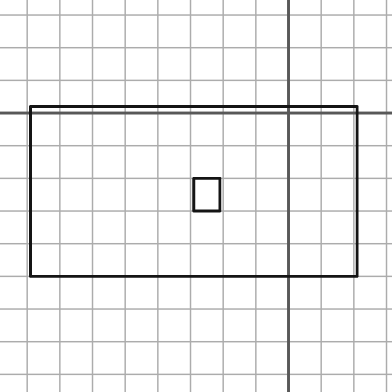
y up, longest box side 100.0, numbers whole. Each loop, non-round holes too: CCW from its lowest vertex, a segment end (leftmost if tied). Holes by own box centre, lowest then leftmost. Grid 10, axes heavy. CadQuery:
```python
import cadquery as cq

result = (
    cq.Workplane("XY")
    .moveTo(-79.0, -50.0)
    .lineTo(21.0, -50.0)
    .lineTo(21.0, 2.0)
    .lineTo(-79.0, 2.0)
    .close()
    .moveTo(-29.0, -30.0)
    .lineTo(-21.0, -30.0)
    .lineTo(-21.0, -20.0)
    .lineTo(-29.0, -20.0)
    .close()
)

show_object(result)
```